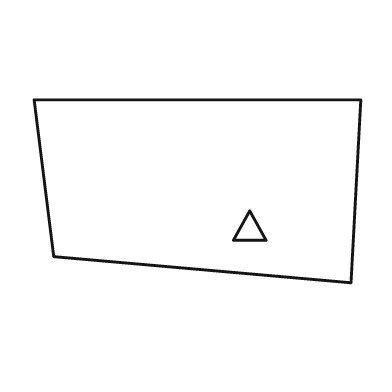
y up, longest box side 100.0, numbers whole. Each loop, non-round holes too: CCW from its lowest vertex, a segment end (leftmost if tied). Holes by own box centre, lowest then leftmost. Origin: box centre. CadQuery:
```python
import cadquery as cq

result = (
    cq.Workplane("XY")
    .moveTo(47.0, -28.0)
    .lineTo(50.0, 28.0)
    .lineTo(-50.0, 28.0)
    .lineTo(-44.0, -20.0)
    .close()
    .moveTo(11.0, -15.0)
    .lineTo(21.0, -15.0)
    .lineTo(16.0, -6.0)
    .close()
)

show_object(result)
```